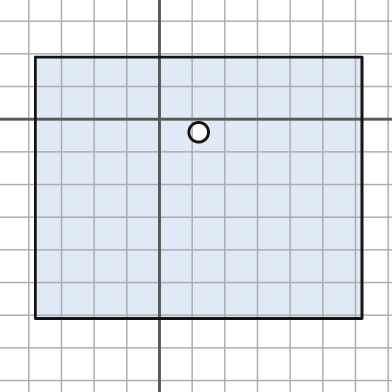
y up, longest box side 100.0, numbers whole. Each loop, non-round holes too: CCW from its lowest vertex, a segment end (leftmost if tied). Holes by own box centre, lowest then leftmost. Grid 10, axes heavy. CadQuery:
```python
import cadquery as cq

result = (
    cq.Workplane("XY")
    .moveTo(-38.0, -61.0)
    .lineTo(62.0, -61.0)
    .lineTo(62.0, 19.0)
    .lineTo(-38.0, 19.0)
    .close()
    .moveTo(12.0, -4.0)
    .circle(3.0)
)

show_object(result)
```